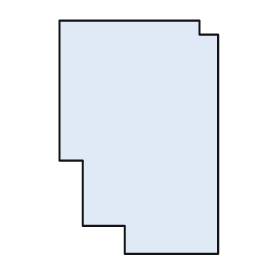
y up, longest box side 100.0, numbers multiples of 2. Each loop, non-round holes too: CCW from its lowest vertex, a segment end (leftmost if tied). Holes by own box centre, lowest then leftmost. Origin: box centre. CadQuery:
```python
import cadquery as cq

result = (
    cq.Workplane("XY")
    .moveTo(-6.0, -50.0)
    .lineTo(34.0, -50.0)
    .lineTo(34.0, 44.0)
    .lineTo(26.0, 44.0)
    .lineTo(26.0, 50.0)
    .lineTo(-34.0, 50.0)
    .lineTo(-34.0, -10.0)
    .lineTo(-24.0, -10.0)
    .lineTo(-24.0, -38.0)
    .lineTo(-6.0, -38.0)
    .close()
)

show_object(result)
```